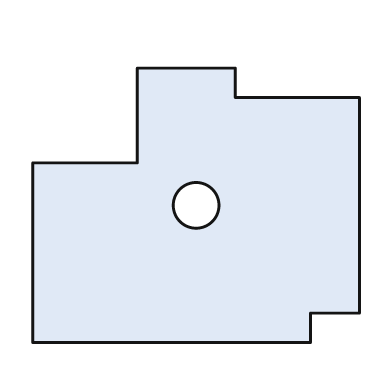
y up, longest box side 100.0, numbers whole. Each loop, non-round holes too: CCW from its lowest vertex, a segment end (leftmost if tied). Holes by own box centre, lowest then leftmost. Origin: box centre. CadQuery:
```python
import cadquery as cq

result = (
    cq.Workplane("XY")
    .moveTo(-50.0, -42.0)
    .lineTo(35.0, -42.0)
    .lineTo(35.0, -33.0)
    .lineTo(50.0, -33.0)
    .lineTo(50.0, 33.0)
    .lineTo(12.0, 33.0)
    .lineTo(12.0, 42.0)
    .lineTo(-18.0, 42.0)
    .lineTo(-18.0, 13.0)
    .lineTo(-50.0, 13.0)
    .close()
    .moveTo(0.0, 0.0)
    .circle(7.0)
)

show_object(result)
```